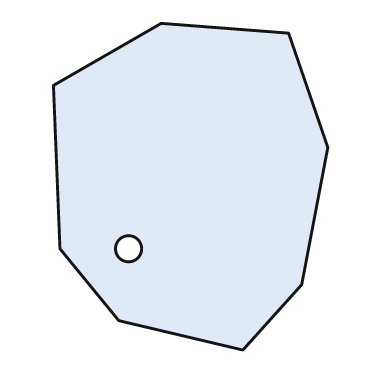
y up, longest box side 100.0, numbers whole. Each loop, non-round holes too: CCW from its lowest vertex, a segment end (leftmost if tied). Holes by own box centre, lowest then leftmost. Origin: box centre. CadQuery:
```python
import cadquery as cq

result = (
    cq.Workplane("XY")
    .moveTo(16.0, -50.0)
    .lineTo(34.0, -30.0)
    .lineTo(42.0, 12.0)
    .lineTo(30.0, 47.0)
    .lineTo(-9.0, 50.0)
    .lineTo(-42.0, 31.0)
    .lineTo(-40.0, -19.0)
    .lineTo(-22.0, -41.0)
    .close()
    .moveTo(-19.0, -19.0)
    .circle(4.0)
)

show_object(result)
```